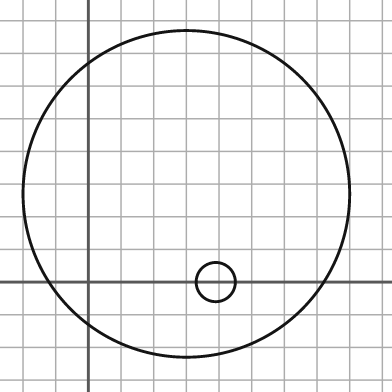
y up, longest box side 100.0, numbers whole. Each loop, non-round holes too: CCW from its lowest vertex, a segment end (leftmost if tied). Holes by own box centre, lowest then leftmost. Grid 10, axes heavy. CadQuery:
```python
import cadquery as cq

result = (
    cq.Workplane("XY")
    .moveTo(30.0, 27.0)
    .circle(50.0)
    .moveTo(39.0, 0.0)
    .circle(6.0)
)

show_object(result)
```